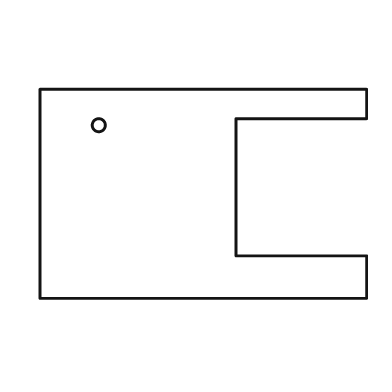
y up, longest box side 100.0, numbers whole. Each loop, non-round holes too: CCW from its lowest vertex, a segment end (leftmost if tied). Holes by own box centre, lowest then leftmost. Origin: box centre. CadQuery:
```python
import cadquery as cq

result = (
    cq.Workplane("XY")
    .moveTo(-50.0, -32.0)
    .lineTo(50.0, -32.0)
    .lineTo(50.0, -19.0)
    .lineTo(10.0, -19.0)
    .lineTo(10.0, 23.0)
    .lineTo(50.0, 23.0)
    .lineTo(50.0, 32.0)
    .lineTo(-50.0, 32.0)
    .close()
    .moveTo(-32.0, 21.0)
    .circle(2.0)
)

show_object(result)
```